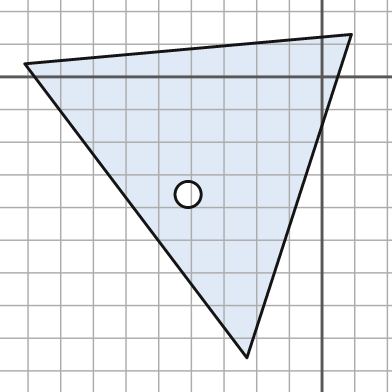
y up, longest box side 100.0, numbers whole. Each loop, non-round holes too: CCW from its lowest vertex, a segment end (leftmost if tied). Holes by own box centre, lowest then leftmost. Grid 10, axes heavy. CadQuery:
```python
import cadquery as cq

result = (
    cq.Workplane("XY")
    .moveTo(-23.0, -86.0)
    .lineTo(9.0, 13.0)
    .lineTo(-91.0, 4.0)
    .close()
    .moveTo(-41.0, -36.0)
    .circle(4.0)
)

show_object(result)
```